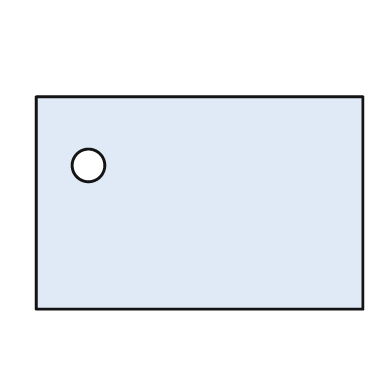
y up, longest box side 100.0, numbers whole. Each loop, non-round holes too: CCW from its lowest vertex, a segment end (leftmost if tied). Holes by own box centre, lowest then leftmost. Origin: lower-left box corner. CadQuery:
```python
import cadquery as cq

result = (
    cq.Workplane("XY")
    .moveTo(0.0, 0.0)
    .lineTo(100.0, 0.0)
    .lineTo(100.0, 65.0)
    .lineTo(0.0, 65.0)
    .close()
    .moveTo(16.0, 44.0)
    .circle(5.0)
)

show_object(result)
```